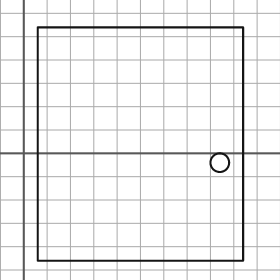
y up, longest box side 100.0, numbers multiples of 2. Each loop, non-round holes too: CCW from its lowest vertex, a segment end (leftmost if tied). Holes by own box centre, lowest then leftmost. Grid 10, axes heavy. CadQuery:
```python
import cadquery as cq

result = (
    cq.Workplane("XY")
    .moveTo(6.0, -46.0)
    .lineTo(94.0, -46.0)
    .lineTo(94.0, 54.0)
    .lineTo(6.0, 54.0)
    .close()
    .moveTo(84.0, -4.0)
    .circle(4.0)
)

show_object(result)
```